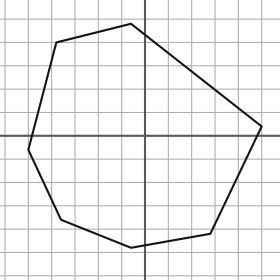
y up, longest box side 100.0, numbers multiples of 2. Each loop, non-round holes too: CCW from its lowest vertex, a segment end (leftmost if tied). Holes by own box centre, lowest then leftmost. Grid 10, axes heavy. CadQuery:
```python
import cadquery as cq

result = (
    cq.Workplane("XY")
    .moveTo(-6.0, -48.0)
    .lineTo(28.0, -42.0)
    .lineTo(50.0, 4.0)
    .lineTo(-6.0, 48.0)
    .lineTo(-38.0, 40.0)
    .lineTo(-50.0, -6.0)
    .lineTo(-36.0, -36.0)
    .close()
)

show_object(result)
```